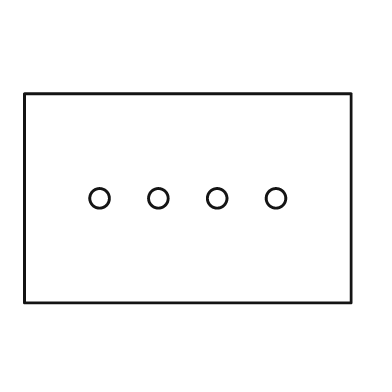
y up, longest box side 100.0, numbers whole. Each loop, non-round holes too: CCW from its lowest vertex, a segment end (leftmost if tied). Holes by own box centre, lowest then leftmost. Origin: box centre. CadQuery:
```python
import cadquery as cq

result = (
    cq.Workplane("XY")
    .moveTo(-50.0, -32.0)
    .lineTo(50.0, -32.0)
    .lineTo(50.0, 32.0)
    .lineTo(-50.0, 32.0)
    .close()
    .moveTo(-27.0, 0.0)
    .circle(3.0)
    .moveTo(-9.0, 0.0)
    .circle(3.0)
    .moveTo(9.0, 0.0)
    .circle(3.0)
    .moveTo(27.0, 0.0)
    .circle(3.0)
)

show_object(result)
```